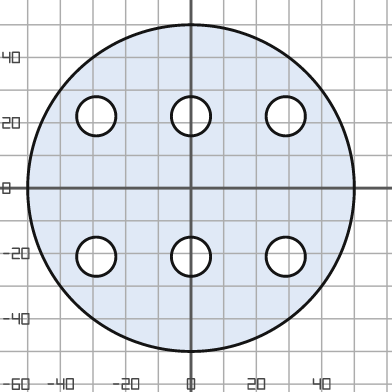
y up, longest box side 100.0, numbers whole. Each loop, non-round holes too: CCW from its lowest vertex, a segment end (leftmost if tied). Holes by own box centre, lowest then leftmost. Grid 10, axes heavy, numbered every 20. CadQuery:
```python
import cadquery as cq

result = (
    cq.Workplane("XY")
    .moveTo(0.0, 0.0)
    .circle(50.0)
    .moveTo(-29.0, -21.0)
    .circle(6.0)
    .moveTo(0.0, -21.0)
    .circle(6.0)
    .moveTo(29.0, -21.0)
    .circle(6.0)
    .moveTo(-29.0, 22.0)
    .circle(6.0)
    .moveTo(0.0, 22.0)
    .circle(6.0)
    .moveTo(29.0, 22.0)
    .circle(6.0)
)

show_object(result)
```